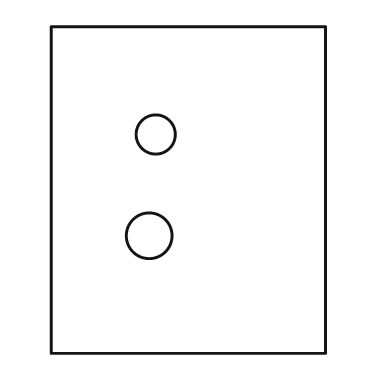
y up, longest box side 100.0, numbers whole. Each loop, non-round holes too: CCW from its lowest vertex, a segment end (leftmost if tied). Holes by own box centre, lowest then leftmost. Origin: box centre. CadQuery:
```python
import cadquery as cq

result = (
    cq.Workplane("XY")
    .moveTo(-42.0, -50.0)
    .lineTo(42.0, -50.0)
    .lineTo(42.0, 50.0)
    .lineTo(-42.0, 50.0)
    .close()
    .moveTo(-12.0, -14.0)
    .circle(7.0)
    .moveTo(-10.0, 17.0)
    .circle(6.0)
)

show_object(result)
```